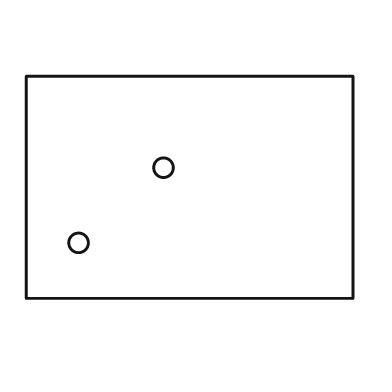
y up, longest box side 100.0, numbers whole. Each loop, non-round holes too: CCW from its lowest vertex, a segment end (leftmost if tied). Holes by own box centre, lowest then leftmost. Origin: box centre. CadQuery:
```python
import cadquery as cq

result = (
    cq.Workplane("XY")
    .moveTo(-50.0, -34.0)
    .lineTo(50.0, -34.0)
    .lineTo(50.0, 34.0)
    .lineTo(-50.0, 34.0)
    .close()
    .moveTo(-34.0, -17.0)
    .circle(3.0)
    .moveTo(-8.0, 6.0)
    .circle(3.0)
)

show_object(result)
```